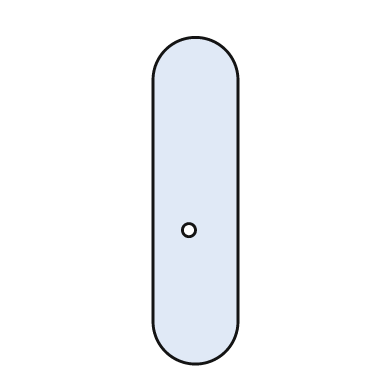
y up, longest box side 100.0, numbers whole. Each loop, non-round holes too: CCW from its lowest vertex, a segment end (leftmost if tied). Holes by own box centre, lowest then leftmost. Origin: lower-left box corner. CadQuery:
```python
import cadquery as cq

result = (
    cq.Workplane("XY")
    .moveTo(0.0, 13.0)
    .threePointArc((13.0, 0.0), (26.0, 13.0))
    .lineTo(26.0, 87.0)
    .threePointArc((13.0, 100.0), (0.0, 87.0))
    .close()
    .moveTo(11.0, 41.0)
    .circle(2.0)
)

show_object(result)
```